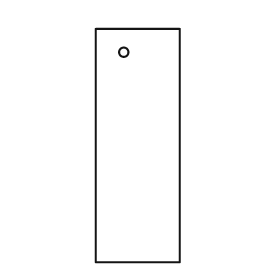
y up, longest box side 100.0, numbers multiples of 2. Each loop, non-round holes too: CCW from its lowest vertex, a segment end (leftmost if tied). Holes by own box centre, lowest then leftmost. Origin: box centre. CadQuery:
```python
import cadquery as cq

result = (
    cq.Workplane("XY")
    .moveTo(-18.0, -50.0)
    .lineTo(18.0, -50.0)
    .lineTo(18.0, 50.0)
    .lineTo(-18.0, 50.0)
    .close()
    .moveTo(-6.0, 40.0)
    .circle(2.0)
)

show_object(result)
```